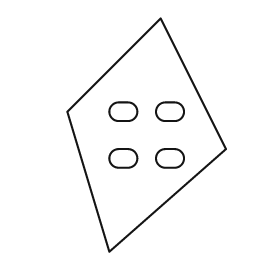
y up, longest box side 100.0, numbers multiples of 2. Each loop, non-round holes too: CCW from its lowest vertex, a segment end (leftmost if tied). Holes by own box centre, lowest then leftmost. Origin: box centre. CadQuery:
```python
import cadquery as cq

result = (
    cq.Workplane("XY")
    .moveTo(-16.0, -50.0)
    .lineTo(34.0, -6.0)
    .lineTo(6.0, 50.0)
    .lineTo(-34.0, 10.0)
    .close()
    .moveTo(-12.0, -14.0)
    .lineTo(-8.0, -14.0)
    .threePointArc((-4.0, -10.0), (-8.0, -6.0))
    .lineTo(-12.0, -6.0)
    .threePointArc((-16.0, -10.0), (-12.0, -14.0))
    .close()
    .moveTo(8.0, -14.0)
    .lineTo(12.0, -14.0)
    .threePointArc((16.0, -10.0), (12.0, -6.0))
    .lineTo(8.0, -6.0)
    .threePointArc((4.0, -10.0), (8.0, -14.0))
    .close()
    .moveTo(-12.0, 6.0)
    .lineTo(-8.0, 6.0)
    .threePointArc((-4.0, 10.0), (-8.0, 14.0))
    .lineTo(-12.0, 14.0)
    .threePointArc((-16.0, 10.0), (-12.0, 6.0))
    .close()
    .moveTo(8.0, 6.0)
    .lineTo(12.0, 6.0)
    .threePointArc((16.0, 10.0), (12.0, 14.0))
    .lineTo(8.0, 14.0)
    .threePointArc((4.0, 10.0), (8.0, 6.0))
    .close()
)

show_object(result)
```